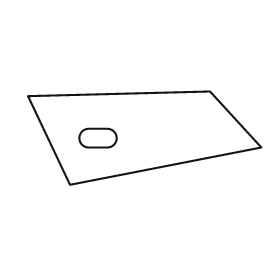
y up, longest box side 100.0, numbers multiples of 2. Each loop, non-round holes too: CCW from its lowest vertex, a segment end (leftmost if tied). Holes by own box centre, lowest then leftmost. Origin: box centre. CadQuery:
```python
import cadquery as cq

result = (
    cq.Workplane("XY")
    .moveTo(-32.0, -20.0)
    .lineTo(50.0, -4.0)
    .lineTo(28.0, 20.0)
    .lineTo(-50.0, 18.0)
    .close()
    .moveTo(-24.0, -4.0)
    .lineTo(-16.0, -4.0)
    .threePointArc((-12.0, 0.0), (-16.0, 4.0))
    .lineTo(-24.0, 4.0)
    .threePointArc((-28.0, 0.0), (-24.0, -4.0))
    .close()
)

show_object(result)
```